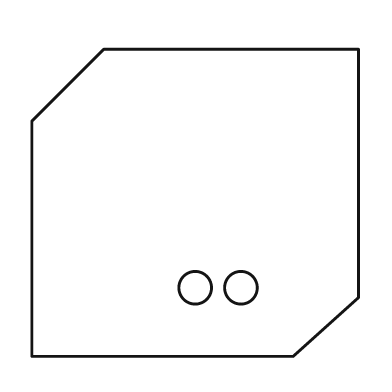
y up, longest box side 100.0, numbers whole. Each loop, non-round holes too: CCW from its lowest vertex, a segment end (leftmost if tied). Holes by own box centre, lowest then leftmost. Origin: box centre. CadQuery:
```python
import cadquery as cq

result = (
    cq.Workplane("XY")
    .moveTo(-50.0, -47.0)
    .lineTo(30.0, -47.0)
    .lineTo(50.0, -29.0)
    .lineTo(50.0, 47.0)
    .lineTo(-28.0, 47.0)
    .lineTo(-50.0, 25.0)
    .close()
    .moveTo(0.0, -26.0)
    .circle(5.0)
    .moveTo(14.0, -26.0)
    .circle(5.0)
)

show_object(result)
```